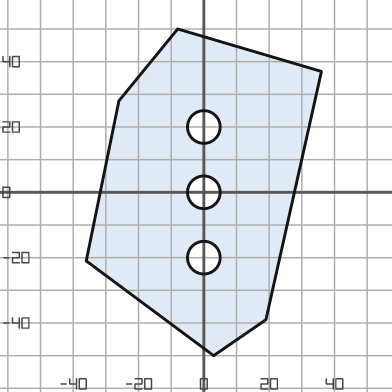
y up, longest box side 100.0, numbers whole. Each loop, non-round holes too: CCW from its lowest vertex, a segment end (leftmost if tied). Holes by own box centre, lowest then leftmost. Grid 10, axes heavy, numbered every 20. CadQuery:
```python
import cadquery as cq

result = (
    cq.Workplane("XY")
    .moveTo(3.0, -50.0)
    .lineTo(19.0, -39.0)
    .lineTo(36.0, 37.0)
    .lineTo(-8.0, 50.0)
    .lineTo(-26.0, 28.0)
    .lineTo(-36.0, -21.0)
    .close()
    .moveTo(0.0, -20.0)
    .circle(5.0)
    .moveTo(0.0, 0.0)
    .circle(5.0)
    .moveTo(0.0, 20.0)
    .circle(5.0)
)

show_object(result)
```